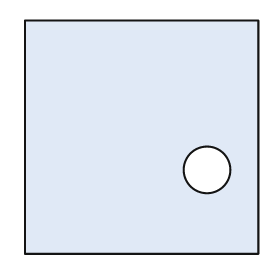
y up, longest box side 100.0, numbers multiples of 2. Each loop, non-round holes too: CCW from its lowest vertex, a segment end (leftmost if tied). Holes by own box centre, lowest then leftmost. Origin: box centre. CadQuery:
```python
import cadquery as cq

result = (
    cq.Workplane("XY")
    .moveTo(-50.0, -50.0)
    .lineTo(50.0, -50.0)
    .lineTo(50.0, 50.0)
    .lineTo(-50.0, 50.0)
    .close()
    .moveTo(28.0, -14.0)
    .circle(10.0)
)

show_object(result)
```